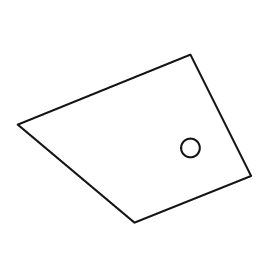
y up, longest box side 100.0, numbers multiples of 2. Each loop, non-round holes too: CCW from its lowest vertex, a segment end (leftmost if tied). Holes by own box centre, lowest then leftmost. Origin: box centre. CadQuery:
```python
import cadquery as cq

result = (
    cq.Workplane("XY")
    .moveTo(0.0, -36.0)
    .lineTo(50.0, -16.0)
    .lineTo(24.0, 36.0)
    .lineTo(-50.0, 6.0)
    .close()
    .moveTo(24.0, -4.0)
    .circle(4.0)
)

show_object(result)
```